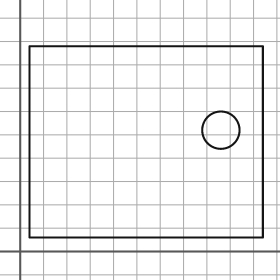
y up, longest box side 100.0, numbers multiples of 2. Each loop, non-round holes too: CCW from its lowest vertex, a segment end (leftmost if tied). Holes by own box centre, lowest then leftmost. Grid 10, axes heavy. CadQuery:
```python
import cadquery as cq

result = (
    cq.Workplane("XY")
    .moveTo(4.0, 6.0)
    .lineTo(104.0, 6.0)
    .lineTo(104.0, 88.0)
    .lineTo(4.0, 88.0)
    .close()
    .moveTo(86.0, 52.0)
    .circle(8.0)
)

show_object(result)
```